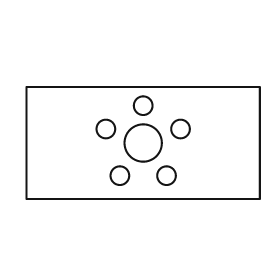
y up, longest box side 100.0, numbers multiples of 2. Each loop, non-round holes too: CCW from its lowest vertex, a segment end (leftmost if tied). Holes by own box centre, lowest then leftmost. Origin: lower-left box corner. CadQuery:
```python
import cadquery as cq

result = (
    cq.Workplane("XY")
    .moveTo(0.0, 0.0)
    .lineTo(100.0, 0.0)
    .lineTo(100.0, 48.0)
    .lineTo(0.0, 48.0)
    .close()
    .moveTo(40.0, 10.0)
    .circle(4.0)
    .moveTo(60.0, 10.0)
    .circle(4.0)
    .moveTo(50.0, 24.0)
    .circle(8.0)
    .moveTo(34.0, 30.0)
    .circle(4.0)
    .moveTo(66.0, 30.0)
    .circle(4.0)
    .moveTo(50.0, 40.0)
    .circle(4.0)
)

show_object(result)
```